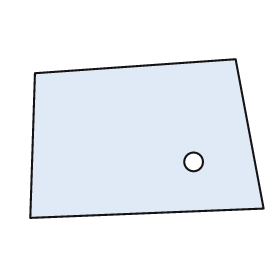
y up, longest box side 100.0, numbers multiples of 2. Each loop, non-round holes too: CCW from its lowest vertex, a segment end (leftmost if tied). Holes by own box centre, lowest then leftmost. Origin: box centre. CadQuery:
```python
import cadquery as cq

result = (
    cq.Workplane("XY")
    .moveTo(-50.0, -34.0)
    .lineTo(50.0, -30.0)
    .lineTo(38.0, 34.0)
    .lineTo(-48.0, 28.0)
    .close()
    .moveTo(20.0, -10.0)
    .circle(4.0)
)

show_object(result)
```